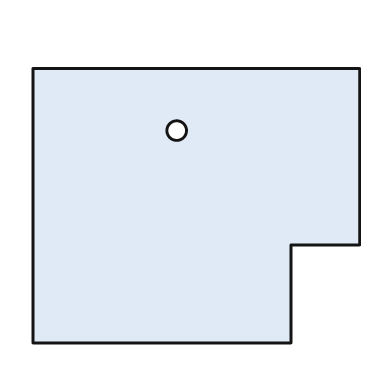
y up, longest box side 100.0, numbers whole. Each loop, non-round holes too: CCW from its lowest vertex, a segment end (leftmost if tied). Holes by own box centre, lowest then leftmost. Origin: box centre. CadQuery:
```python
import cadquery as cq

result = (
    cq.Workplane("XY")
    .moveTo(-50.0, -42.0)
    .lineTo(29.0, -42.0)
    .lineTo(29.0, -12.0)
    .lineTo(50.0, -12.0)
    .lineTo(50.0, 42.0)
    .lineTo(-50.0, 42.0)
    .close()
    .moveTo(-6.0, 23.0)
    .circle(3.0)
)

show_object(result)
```